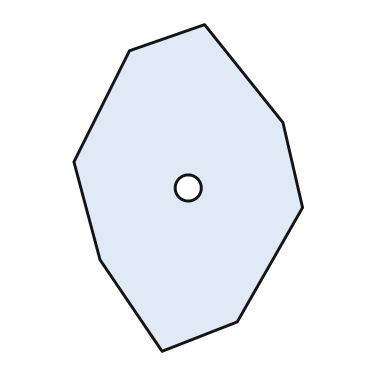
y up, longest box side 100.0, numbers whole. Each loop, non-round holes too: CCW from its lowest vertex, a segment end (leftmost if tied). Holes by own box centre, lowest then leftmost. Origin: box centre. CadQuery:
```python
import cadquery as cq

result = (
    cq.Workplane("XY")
    .moveTo(-8.0, -50.0)
    .lineTo(15.0, -41.0)
    .lineTo(35.0, -6.0)
    .lineTo(29.0, 20.0)
    .lineTo(5.0, 50.0)
    .lineTo(-18.0, 42.0)
    .lineTo(-35.0, 8.0)
    .lineTo(-27.0, -22.0)
    .close()
    .moveTo(0.0, 0.0)
    .circle(4.0)
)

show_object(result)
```